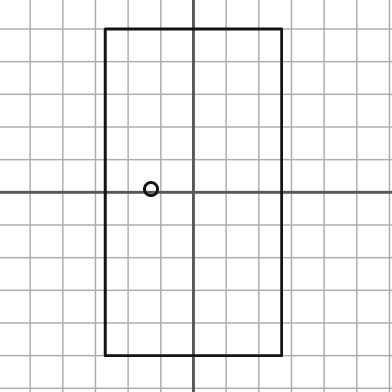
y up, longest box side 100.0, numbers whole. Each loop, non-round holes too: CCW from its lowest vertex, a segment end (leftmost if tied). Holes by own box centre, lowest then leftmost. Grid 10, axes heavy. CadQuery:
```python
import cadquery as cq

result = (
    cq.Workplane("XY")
    .moveTo(-27.0, -50.0)
    .lineTo(27.0, -50.0)
    .lineTo(27.0, 50.0)
    .lineTo(-27.0, 50.0)
    .close()
    .moveTo(-13.0, 1.0)
    .circle(2.0)
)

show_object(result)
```